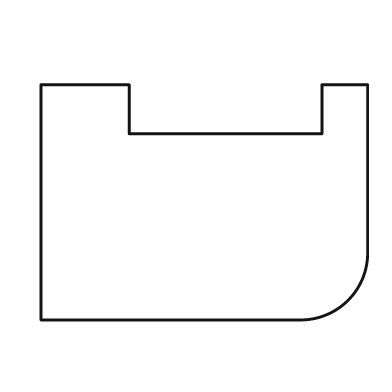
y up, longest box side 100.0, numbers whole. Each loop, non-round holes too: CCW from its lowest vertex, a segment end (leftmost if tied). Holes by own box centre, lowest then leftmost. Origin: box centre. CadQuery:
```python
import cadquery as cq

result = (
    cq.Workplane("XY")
    .moveTo(-50.0, -36.0)
    .lineTo(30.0, -36.0)
    .threePointArc((44.0, -30.0), (50.0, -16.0))
    .lineTo(50.0, 36.0)
    .lineTo(36.0, 36.0)
    .lineTo(36.0, 21.0)
    .lineTo(-23.0, 21.0)
    .lineTo(-23.0, 36.0)
    .lineTo(-50.0, 36.0)
    .close()
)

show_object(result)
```